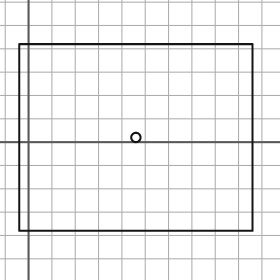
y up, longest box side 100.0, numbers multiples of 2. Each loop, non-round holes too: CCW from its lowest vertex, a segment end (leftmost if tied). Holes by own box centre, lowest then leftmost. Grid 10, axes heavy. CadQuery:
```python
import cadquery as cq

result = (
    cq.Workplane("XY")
    .moveTo(-4.0, -38.0)
    .lineTo(96.0, -38.0)
    .lineTo(96.0, 42.0)
    .lineTo(-4.0, 42.0)
    .close()
    .moveTo(46.0, 2.0)
    .circle(2.0)
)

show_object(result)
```